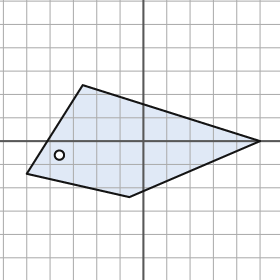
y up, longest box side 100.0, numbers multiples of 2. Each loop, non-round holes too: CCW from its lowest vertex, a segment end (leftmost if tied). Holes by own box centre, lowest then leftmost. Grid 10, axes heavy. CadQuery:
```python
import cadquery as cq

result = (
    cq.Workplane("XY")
    .moveTo(-6.0, -24.0)
    .lineTo(50.0, 0.0)
    .lineTo(-26.0, 24.0)
    .lineTo(-50.0, -14.0)
    .close()
    .moveTo(-36.0, -6.0)
    .circle(2.0)
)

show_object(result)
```